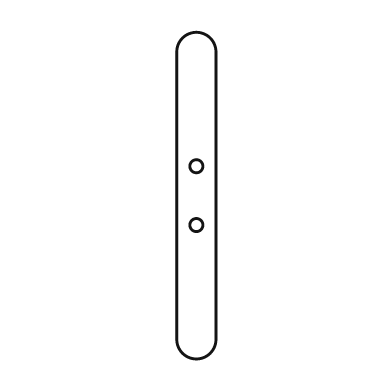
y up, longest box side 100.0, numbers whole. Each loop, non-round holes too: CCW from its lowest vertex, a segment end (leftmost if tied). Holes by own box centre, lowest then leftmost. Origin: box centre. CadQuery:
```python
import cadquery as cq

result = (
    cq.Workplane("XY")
    .moveTo(-6.0, -44.0)
    .threePointArc((0.0, -50.0), (6.0, -44.0))
    .lineTo(6.0, 44.0)
    .threePointArc((0.0, 50.0), (-6.0, 44.0))
    .close()
    .moveTo(0.0, -9.0)
    .circle(2.0)
    .moveTo(0.0, 9.0)
    .circle(2.0)
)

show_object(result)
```